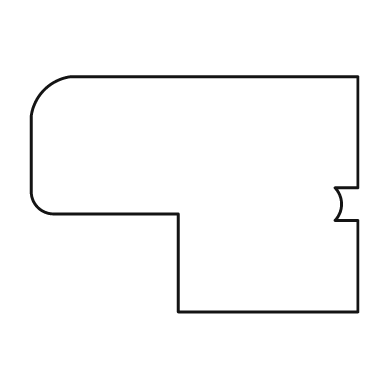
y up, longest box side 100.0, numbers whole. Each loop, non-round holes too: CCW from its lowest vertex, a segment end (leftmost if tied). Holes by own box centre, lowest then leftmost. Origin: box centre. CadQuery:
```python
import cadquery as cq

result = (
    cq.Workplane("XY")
    .moveTo(-5.0, -36.0)
    .lineTo(50.0, -36.0)
    .lineTo(50.0, -8.0)
    .lineTo(43.0, -8.0)
    .threePointArc((45.0, -3.0), (43.0, 2.0))
    .lineTo(50.0, 2.0)
    .lineTo(50.0, 36.0)
    .lineTo(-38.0, 36.0)
    .threePointArc((-46.0, 32.0), (-50.0, 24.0))
    .lineTo(-50.0, 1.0)
    .threePointArc((-48.0, -4.0), (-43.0, -6.0))
    .lineTo(-5.0, -6.0)
    .close()
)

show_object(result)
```